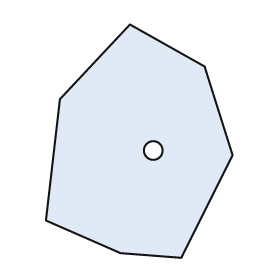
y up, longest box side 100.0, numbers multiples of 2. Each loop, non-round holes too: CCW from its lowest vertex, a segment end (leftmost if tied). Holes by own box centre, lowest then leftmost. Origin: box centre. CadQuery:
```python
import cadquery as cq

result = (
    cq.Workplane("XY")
    .moveTo(18.0, -50.0)
    .lineTo(40.0, -6.0)
    .lineTo(28.0, 32.0)
    .lineTo(-4.0, 50.0)
    .lineTo(-34.0, 18.0)
    .lineTo(-40.0, -34.0)
    .lineTo(-8.0, -48.0)
    .close()
    .moveTo(6.0, -4.0)
    .circle(4.0)
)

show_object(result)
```